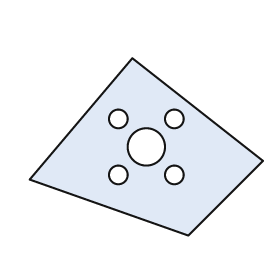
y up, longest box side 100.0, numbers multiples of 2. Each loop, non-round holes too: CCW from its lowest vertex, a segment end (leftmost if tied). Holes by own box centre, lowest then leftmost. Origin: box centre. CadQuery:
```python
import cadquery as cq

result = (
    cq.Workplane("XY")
    .moveTo(18.0, -38.0)
    .lineTo(50.0, -6.0)
    .lineTo(-6.0, 38.0)
    .lineTo(-50.0, -14.0)
    .close()
    .moveTo(-12.0, -12.0)
    .circle(4.0)
    .moveTo(12.0, -12.0)
    .circle(4.0)
    .moveTo(0.0, 0.0)
    .circle(8.0)
    .moveTo(-12.0, 12.0)
    .circle(4.0)
    .moveTo(12.0, 12.0)
    .circle(4.0)
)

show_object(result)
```